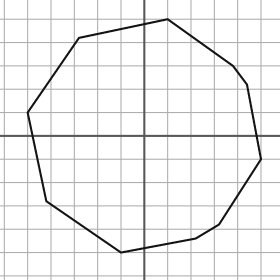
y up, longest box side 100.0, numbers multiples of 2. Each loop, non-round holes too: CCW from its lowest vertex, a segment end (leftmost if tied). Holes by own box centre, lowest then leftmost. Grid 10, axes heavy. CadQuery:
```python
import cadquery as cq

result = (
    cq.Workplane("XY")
    .moveTo(-10.0, -50.0)
    .lineTo(22.0, -44.0)
    .lineTo(32.0, -38.0)
    .lineTo(50.0, -10.0)
    .lineTo(44.0, 22.0)
    .lineTo(38.0, 30.0)
    .lineTo(10.0, 50.0)
    .lineTo(-28.0, 42.0)
    .lineTo(-50.0, 10.0)
    .lineTo(-42.0, -28.0)
    .close()
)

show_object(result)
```